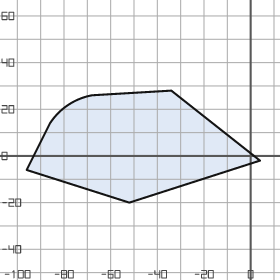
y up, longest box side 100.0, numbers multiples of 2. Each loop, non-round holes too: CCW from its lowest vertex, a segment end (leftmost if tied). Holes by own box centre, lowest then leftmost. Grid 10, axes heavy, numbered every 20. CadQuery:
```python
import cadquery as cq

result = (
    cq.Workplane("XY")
    .moveTo(-52.0, -20.0)
    .lineTo(4.0, -2.0)
    .lineTo(-34.0, 28.0)
    .lineTo(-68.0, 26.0)
    .threePointArc((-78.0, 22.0), (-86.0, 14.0))
    .lineTo(-96.0, -6.0)
    .close()
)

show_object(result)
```